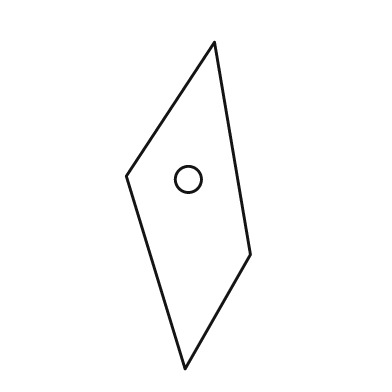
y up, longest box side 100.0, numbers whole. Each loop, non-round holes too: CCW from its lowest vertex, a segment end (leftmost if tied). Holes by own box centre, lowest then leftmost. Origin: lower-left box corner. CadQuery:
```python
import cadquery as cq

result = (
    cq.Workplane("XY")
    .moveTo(18.0, 0.0)
    .lineTo(38.0, 35.0)
    .lineTo(27.0, 100.0)
    .lineTo(0.0, 59.0)
    .close()
    .moveTo(19.0, 58.0)
    .circle(4.0)
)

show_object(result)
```